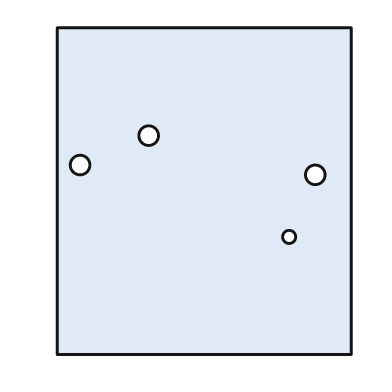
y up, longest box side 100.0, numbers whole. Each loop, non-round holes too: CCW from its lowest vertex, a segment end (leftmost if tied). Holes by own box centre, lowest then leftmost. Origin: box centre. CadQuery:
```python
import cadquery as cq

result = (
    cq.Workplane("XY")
    .moveTo(-45.0, -50.0)
    .lineTo(45.0, -50.0)
    .lineTo(45.0, 50.0)
    .lineTo(-45.0, 50.0)
    .close()
    .moveTo(26.0, -14.0)
    .circle(2.0)
    .moveTo(34.0, 5.0)
    .circle(3.0)
    .moveTo(-38.0, 8.0)
    .circle(3.0)
    .moveTo(-17.0, 17.0)
    .circle(3.0)
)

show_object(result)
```